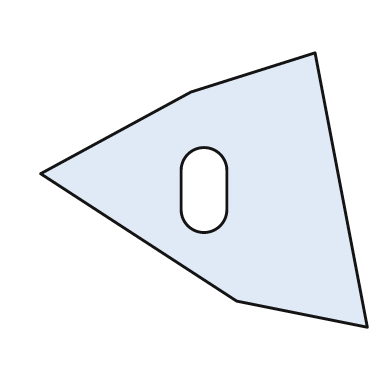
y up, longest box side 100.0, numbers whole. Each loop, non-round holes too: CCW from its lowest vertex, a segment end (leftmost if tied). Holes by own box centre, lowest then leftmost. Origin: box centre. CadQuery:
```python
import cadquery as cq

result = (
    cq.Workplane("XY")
    .moveTo(50.0, -42.0)
    .lineTo(34.0, 42.0)
    .lineTo(-4.0, 30.0)
    .lineTo(-50.0, 5.0)
    .lineTo(10.0, -34.0)
    .close()
    .moveTo(-7.0, -6.0)
    .threePointArc((0.0, -13.0), (7.0, -6.0))
    .lineTo(7.0, 6.0)
    .threePointArc((0.0, 13.0), (-7.0, 6.0))
    .close()
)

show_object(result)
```